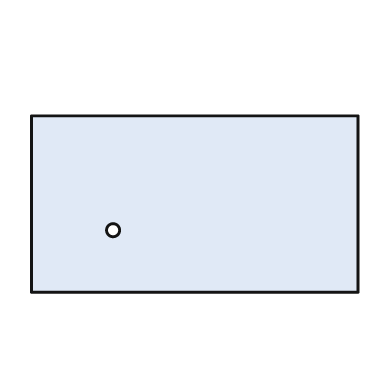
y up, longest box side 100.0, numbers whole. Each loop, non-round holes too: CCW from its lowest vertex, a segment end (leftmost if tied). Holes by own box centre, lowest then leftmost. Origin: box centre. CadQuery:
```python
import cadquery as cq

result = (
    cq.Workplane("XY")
    .moveTo(-50.0, -27.0)
    .lineTo(50.0, -27.0)
    .lineTo(50.0, 27.0)
    .lineTo(-50.0, 27.0)
    .close()
    .moveTo(-25.0, -8.0)
    .circle(2.0)
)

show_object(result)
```